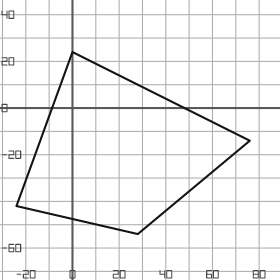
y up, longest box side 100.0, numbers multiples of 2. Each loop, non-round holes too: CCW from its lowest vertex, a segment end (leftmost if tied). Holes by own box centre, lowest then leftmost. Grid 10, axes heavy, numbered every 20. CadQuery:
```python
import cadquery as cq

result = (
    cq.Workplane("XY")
    .moveTo(28.0, -54.0)
    .lineTo(76.0, -14.0)
    .lineTo(0.0, 24.0)
    .lineTo(-24.0, -42.0)
    .close()
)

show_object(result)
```